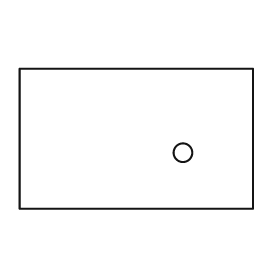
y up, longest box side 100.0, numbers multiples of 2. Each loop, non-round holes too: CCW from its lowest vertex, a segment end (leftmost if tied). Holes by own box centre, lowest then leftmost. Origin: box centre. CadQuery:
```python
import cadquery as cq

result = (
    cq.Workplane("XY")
    .moveTo(-50.0, -30.0)
    .lineTo(50.0, -30.0)
    .lineTo(50.0, 30.0)
    .lineTo(-50.0, 30.0)
    .close()
    .moveTo(20.0, -6.0)
    .circle(4.0)
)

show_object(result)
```